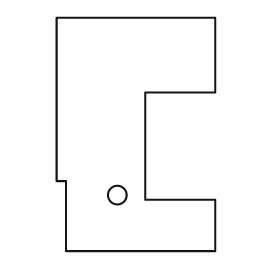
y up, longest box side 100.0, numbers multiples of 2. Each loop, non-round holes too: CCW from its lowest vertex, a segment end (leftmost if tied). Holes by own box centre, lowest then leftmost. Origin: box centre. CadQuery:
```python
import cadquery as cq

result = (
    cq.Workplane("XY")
    .moveTo(-30.0, -50.0)
    .lineTo(34.0, -50.0)
    .lineTo(34.0, -28.0)
    .lineTo(4.0, -28.0)
    .lineTo(4.0, 18.0)
    .lineTo(34.0, 18.0)
    .lineTo(34.0, 50.0)
    .lineTo(-34.0, 50.0)
    .lineTo(-34.0, -20.0)
    .lineTo(-30.0, -20.0)
    .close()
    .moveTo(-8.0, -26.0)
    .circle(4.0)
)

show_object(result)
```